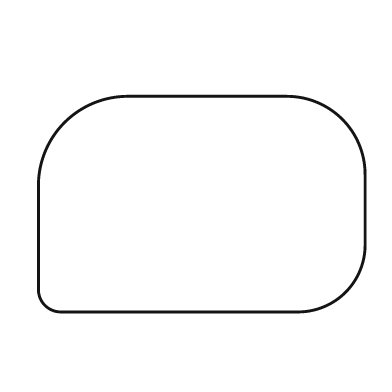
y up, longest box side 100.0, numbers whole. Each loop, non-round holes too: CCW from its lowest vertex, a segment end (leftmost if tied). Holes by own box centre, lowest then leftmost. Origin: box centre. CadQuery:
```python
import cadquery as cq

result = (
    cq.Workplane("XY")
    .moveTo(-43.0, -33.0)
    .lineTo(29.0, -33.0)
    .threePointArc((44.0, -27.0), (50.0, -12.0))
    .lineTo(50.0, 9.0)
    .threePointArc((43.0, 26.0), (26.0, 33.0))
    .lineTo(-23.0, 33.0)
    .threePointArc((-42.0, 25.0), (-50.0, 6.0))
    .lineTo(-50.0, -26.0)
    .threePointArc((-48.0, -31.0), (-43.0, -33.0))
    .close()
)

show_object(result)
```